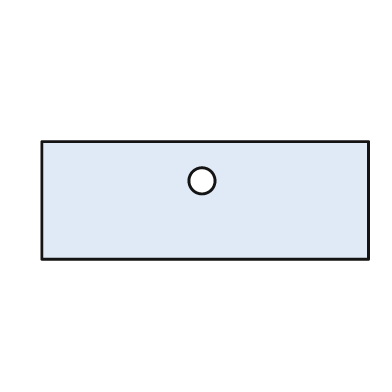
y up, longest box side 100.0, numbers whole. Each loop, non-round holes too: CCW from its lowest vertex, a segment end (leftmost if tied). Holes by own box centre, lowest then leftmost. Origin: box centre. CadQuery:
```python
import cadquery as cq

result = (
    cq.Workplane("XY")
    .moveTo(-50.0, -18.0)
    .lineTo(50.0, -18.0)
    .lineTo(50.0, 18.0)
    .lineTo(-50.0, 18.0)
    .close()
    .moveTo(-1.0, 6.0)
    .circle(4.0)
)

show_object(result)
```